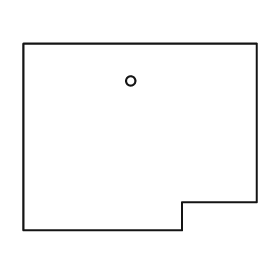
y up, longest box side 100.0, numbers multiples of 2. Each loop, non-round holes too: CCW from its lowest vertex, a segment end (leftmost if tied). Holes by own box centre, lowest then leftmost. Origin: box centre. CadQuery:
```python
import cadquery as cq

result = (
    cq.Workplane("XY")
    .moveTo(-50.0, -40.0)
    .lineTo(18.0, -40.0)
    .lineTo(18.0, -28.0)
    .lineTo(50.0, -28.0)
    .lineTo(50.0, 40.0)
    .lineTo(-50.0, 40.0)
    .close()
    .moveTo(-4.0, 24.0)
    .circle(2.0)
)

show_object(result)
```